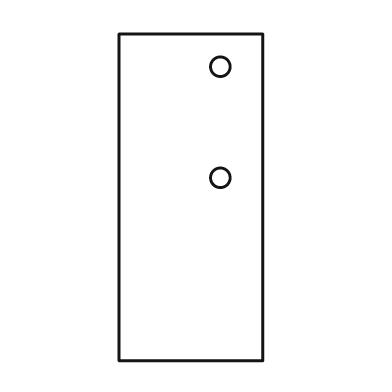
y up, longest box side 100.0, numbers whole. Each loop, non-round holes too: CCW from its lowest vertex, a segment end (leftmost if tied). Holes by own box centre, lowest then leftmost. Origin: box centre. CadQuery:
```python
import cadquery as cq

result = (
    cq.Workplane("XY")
    .moveTo(-22.0, -50.0)
    .lineTo(22.0, -50.0)
    .lineTo(22.0, 50.0)
    .lineTo(-22.0, 50.0)
    .close()
    .moveTo(9.0, 6.0)
    .circle(3.0)
    .moveTo(9.0, 40.0)
    .circle(3.0)
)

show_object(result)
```